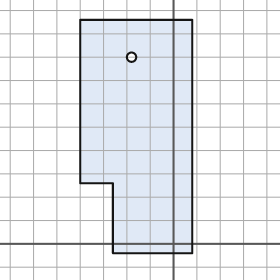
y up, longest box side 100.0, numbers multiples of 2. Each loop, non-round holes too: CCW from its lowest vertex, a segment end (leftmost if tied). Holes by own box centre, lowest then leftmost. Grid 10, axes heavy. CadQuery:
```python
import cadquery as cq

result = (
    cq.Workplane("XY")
    .moveTo(-26.0, -4.0)
    .lineTo(8.0, -4.0)
    .lineTo(8.0, 96.0)
    .lineTo(-40.0, 96.0)
    .lineTo(-40.0, 26.0)
    .lineTo(-26.0, 26.0)
    .close()
    .moveTo(-18.0, 80.0)
    .circle(2.0)
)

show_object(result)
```